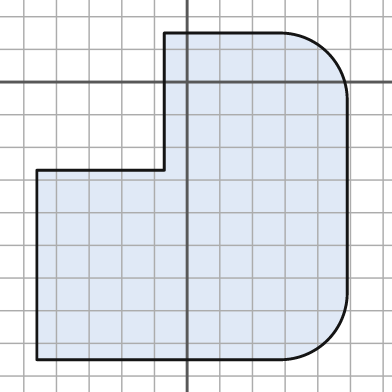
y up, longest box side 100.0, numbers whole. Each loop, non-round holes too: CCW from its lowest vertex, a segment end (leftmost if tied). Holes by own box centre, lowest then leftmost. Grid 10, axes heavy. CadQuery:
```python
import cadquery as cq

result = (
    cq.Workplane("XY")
    .moveTo(-46.0, -85.0)
    .lineTo(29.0, -85.0)
    .threePointArc((43.0, -79.0), (49.0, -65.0))
    .lineTo(49.0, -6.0)
    .threePointArc((43.0, 9.0), (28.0, 15.0))
    .lineTo(-7.0, 15.0)
    .lineTo(-7.0, -27.0)
    .lineTo(-46.0, -27.0)
    .close()
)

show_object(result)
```